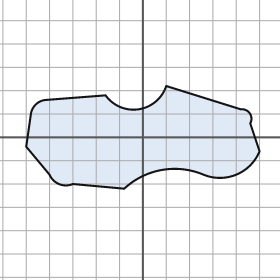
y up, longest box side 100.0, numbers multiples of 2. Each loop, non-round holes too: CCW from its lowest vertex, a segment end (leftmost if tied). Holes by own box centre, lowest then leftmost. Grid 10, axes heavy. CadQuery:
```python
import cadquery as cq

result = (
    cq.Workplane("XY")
    .moveTo(-8.0, -22.0)
    .threePointArc((8.0, -14.0), (26.0, -16.0))
    .threePointArc((40.0, -16.0), (50.0, -6.0))
    .lineTo(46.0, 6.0)
    .threePointArc((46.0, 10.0), (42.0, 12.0))
    .lineTo(10.0, 22.0)
    .threePointArc((-2.0, 12.0), (-16.0, 18.0))
    .lineTo(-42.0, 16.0)
    .threePointArc((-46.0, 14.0), (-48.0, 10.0))
    .lineTo(-50.0, -4.0)
    .lineTo(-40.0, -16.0)
    .threePointArc((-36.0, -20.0), (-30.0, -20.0))
    .close()
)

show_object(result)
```